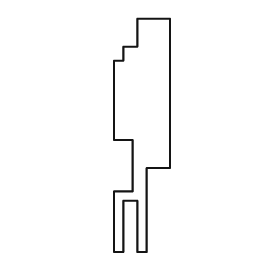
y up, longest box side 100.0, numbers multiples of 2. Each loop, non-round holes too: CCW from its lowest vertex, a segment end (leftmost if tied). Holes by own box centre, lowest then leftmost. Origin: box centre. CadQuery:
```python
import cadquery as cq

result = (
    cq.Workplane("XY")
    .moveTo(-12.0, -50.0)
    .lineTo(-8.0, -50.0)
    .lineTo(-8.0, -28.0)
    .lineTo(-2.0, -28.0)
    .lineTo(-2.0, -50.0)
    .lineTo(2.0, -50.0)
    .lineTo(2.0, -14.0)
    .lineTo(12.0, -14.0)
    .lineTo(12.0, 50.0)
    .lineTo(-2.0, 50.0)
    .lineTo(-2.0, 38.0)
    .lineTo(-8.0, 38.0)
    .lineTo(-8.0, 32.0)
    .lineTo(-12.0, 32.0)
    .lineTo(-12.0, -2.0)
    .lineTo(-4.0, -2.0)
    .lineTo(-4.0, -24.0)
    .lineTo(-12.0, -24.0)
    .close()
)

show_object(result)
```